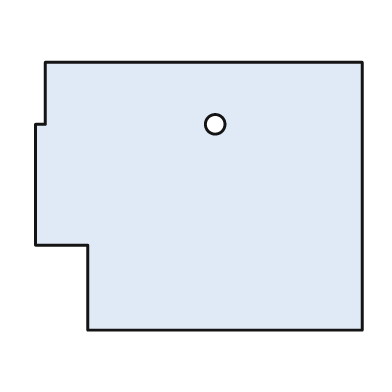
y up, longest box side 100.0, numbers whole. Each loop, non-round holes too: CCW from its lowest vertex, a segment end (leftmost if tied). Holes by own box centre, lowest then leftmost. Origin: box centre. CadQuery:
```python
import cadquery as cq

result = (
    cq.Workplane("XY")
    .moveTo(-34.0, -41.0)
    .lineTo(50.0, -41.0)
    .lineTo(50.0, 41.0)
    .lineTo(-47.0, 41.0)
    .lineTo(-47.0, 22.0)
    .lineTo(-50.0, 22.0)
    .lineTo(-50.0, -15.0)
    .lineTo(-34.0, -15.0)
    .close()
    .moveTo(5.0, 22.0)
    .circle(3.0)
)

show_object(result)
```